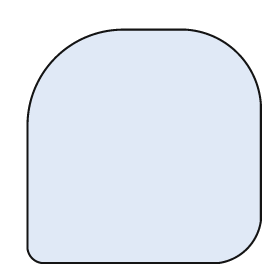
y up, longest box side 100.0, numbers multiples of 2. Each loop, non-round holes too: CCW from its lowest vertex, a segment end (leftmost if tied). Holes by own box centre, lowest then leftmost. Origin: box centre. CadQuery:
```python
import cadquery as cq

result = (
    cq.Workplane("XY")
    .moveTo(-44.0, -50.0)
    .lineTo(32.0, -50.0)
    .threePointArc((44.0, -44.0), (50.0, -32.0))
    .lineTo(50.0, 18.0)
    .threePointArc((40.0, 40.0), (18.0, 50.0))
    .lineTo(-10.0, 50.0)
    .threePointArc((-38.0, 38.0), (-50.0, 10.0))
    .lineTo(-50.0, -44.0)
    .threePointArc((-48.0, -48.0), (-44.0, -50.0))
    .close()
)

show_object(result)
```